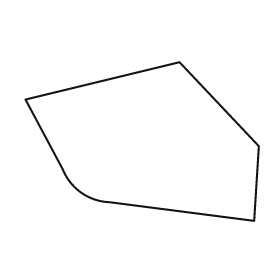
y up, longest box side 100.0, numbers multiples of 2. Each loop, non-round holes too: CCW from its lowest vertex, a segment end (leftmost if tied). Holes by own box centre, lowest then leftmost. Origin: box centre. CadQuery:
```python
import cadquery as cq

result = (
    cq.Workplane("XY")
    .moveTo(48.0, -34.0)
    .lineTo(50.0, -2.0)
    .lineTo(16.0, 34.0)
    .lineTo(-50.0, 18.0)
    .lineTo(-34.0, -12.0)
    .threePointArc((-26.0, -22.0), (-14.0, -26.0))
    .close()
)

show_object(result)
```